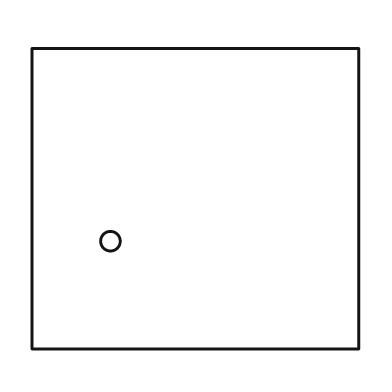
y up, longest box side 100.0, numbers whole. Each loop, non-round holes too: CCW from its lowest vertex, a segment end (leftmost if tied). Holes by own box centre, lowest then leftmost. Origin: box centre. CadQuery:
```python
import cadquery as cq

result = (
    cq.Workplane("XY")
    .moveTo(-50.0, -46.0)
    .lineTo(50.0, -46.0)
    .lineTo(50.0, 46.0)
    .lineTo(-50.0, 46.0)
    .close()
    .moveTo(-26.0, -13.0)
    .circle(3.0)
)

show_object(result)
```